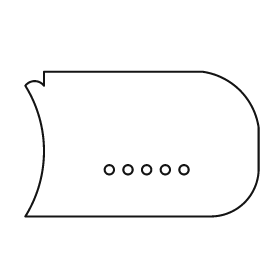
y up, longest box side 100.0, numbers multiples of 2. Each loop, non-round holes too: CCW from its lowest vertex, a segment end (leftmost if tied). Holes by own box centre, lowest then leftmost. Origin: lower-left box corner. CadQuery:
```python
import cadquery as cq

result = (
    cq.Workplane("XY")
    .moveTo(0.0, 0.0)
    .lineTo(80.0, 0.0)
    .threePointArc((94.0, 6.0), (100.0, 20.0))
    .lineTo(100.0, 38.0)
    .threePointArc((92.0, 54.0), (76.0, 62.0))
    .lineTo(8.0, 62.0)
    .lineTo(8.0, 56.0)
    .threePointArc((4.0, 58.0), (0.0, 56.0))
    .threePointArc((8.0, 28.0), (0.0, 0.0))
    .close()
    .moveTo(36.0, 20.0)
    .circle(2.0)
    .moveTo(44.0, 20.0)
    .circle(2.0)
    .moveTo(52.0, 20.0)
    .circle(2.0)
    .moveTo(60.0, 20.0)
    .circle(2.0)
    .moveTo(68.0, 20.0)
    .circle(2.0)
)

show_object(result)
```